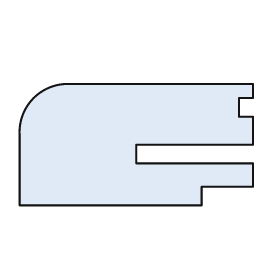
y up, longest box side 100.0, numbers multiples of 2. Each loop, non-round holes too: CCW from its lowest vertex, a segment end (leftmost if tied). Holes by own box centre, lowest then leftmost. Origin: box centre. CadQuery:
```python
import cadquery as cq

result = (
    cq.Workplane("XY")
    .moveTo(-50.0, -26.0)
    .lineTo(28.0, -26.0)
    .lineTo(28.0, -18.0)
    .lineTo(50.0, -18.0)
    .lineTo(50.0, -8.0)
    .lineTo(0.0, -8.0)
    .lineTo(0.0, 0.0)
    .lineTo(50.0, 0.0)
    .lineTo(50.0, 12.0)
    .lineTo(44.0, 12.0)
    .lineTo(44.0, 20.0)
    .lineTo(50.0, 20.0)
    .lineTo(50.0, 26.0)
    .lineTo(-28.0, 26.0)
    .threePointArc((-44.0, 20.0), (-50.0, 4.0))
    .close()
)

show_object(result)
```